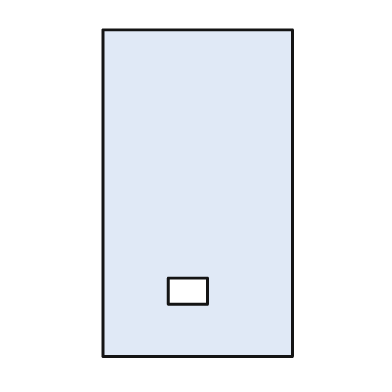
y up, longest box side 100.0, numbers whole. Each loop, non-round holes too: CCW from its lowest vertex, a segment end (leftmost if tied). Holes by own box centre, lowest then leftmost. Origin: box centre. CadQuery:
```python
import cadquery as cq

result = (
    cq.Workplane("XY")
    .moveTo(-29.0, -50.0)
    .lineTo(29.0, -50.0)
    .lineTo(29.0, 50.0)
    .lineTo(-29.0, 50.0)
    .close()
    .moveTo(-9.0, -34.0)
    .lineTo(3.0, -34.0)
    .lineTo(3.0, -26.0)
    .lineTo(-9.0, -26.0)
    .close()
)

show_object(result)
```